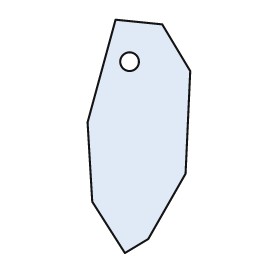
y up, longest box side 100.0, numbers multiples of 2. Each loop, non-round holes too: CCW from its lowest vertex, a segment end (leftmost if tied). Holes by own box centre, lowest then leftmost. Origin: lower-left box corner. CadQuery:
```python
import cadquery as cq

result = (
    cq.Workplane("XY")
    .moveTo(16.0, 0.0)
    .lineTo(26.0, 6.0)
    .lineTo(42.0, 34.0)
    .lineTo(44.0, 78.0)
    .lineTo(32.0, 98.0)
    .lineTo(12.0, 100.0)
    .lineTo(0.0, 56.0)
    .lineTo(2.0, 22.0)
    .close()
    .moveTo(18.0, 82.0)
    .circle(4.0)
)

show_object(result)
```